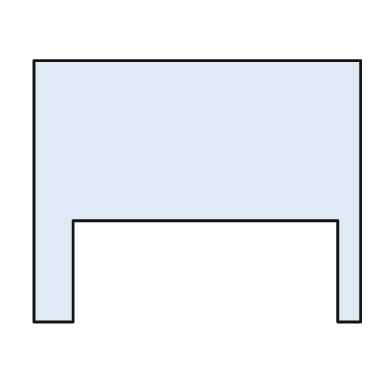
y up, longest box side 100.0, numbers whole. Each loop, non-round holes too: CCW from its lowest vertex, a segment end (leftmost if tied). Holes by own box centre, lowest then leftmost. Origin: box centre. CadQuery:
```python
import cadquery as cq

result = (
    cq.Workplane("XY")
    .moveTo(-50.0, -40.0)
    .lineTo(-38.0, -40.0)
    .lineTo(-38.0, -9.0)
    .lineTo(43.0, -9.0)
    .lineTo(43.0, -40.0)
    .lineTo(50.0, -40.0)
    .lineTo(50.0, 40.0)
    .lineTo(-50.0, 40.0)
    .close()
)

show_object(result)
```